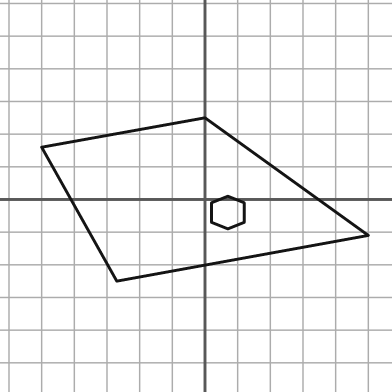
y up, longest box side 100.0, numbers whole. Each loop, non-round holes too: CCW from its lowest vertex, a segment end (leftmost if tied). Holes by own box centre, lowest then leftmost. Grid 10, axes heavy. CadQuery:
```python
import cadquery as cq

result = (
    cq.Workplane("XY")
    .moveTo(-27.0, -25.0)
    .lineTo(50.0, -11.0)
    .lineTo(0.0, 25.0)
    .lineTo(-50.0, 16.0)
    .close()
    .moveTo(7.0, -9.0)
    .lineTo(12.0, -7.0)
    .lineTo(12.0, -1.0)
    .lineTo(7.0, 1.0)
    .lineTo(2.0, -1.0)
    .lineTo(2.0, -7.0)
    .close()
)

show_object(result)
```